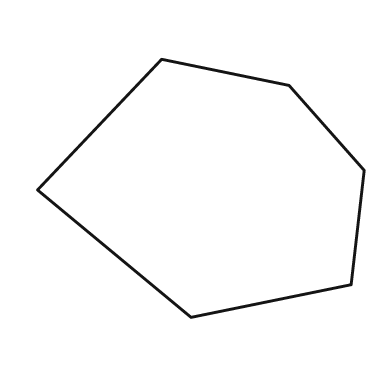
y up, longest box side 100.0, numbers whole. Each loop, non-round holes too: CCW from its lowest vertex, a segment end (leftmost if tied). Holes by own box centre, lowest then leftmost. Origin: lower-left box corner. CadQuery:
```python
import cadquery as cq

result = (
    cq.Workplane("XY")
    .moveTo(47.0, 0.0)
    .lineTo(96.0, 10.0)
    .lineTo(100.0, 45.0)
    .lineTo(77.0, 71.0)
    .lineTo(38.0, 79.0)
    .lineTo(0.0, 39.0)
    .close()
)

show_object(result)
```